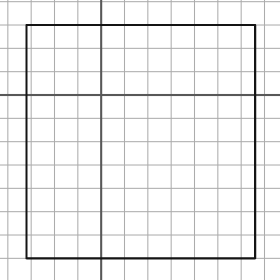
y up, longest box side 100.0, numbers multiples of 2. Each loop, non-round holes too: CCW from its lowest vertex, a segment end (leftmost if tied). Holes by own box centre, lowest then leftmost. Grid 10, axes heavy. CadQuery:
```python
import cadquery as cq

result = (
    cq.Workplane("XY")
    .moveTo(-32.0, -70.0)
    .lineTo(66.0, -70.0)
    .lineTo(66.0, 30.0)
    .lineTo(-32.0, 30.0)
    .close()
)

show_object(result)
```